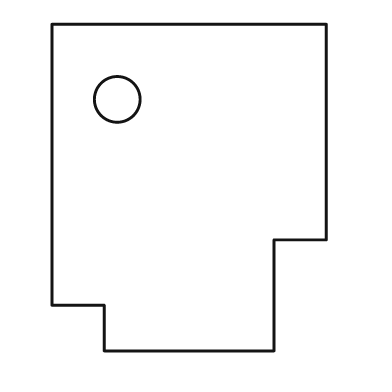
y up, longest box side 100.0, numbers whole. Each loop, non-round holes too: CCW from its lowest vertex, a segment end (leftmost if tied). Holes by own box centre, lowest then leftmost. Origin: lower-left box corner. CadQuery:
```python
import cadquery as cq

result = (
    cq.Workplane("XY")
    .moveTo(16.0, 0.0)
    .lineTo(68.0, 0.0)
    .lineTo(68.0, 34.0)
    .lineTo(84.0, 34.0)
    .lineTo(84.0, 100.0)
    .lineTo(0.0, 100.0)
    .lineTo(0.0, 14.0)
    .lineTo(16.0, 14.0)
    .close()
    .moveTo(20.0, 77.0)
    .circle(7.0)
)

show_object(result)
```